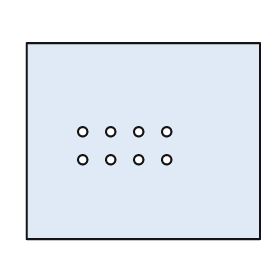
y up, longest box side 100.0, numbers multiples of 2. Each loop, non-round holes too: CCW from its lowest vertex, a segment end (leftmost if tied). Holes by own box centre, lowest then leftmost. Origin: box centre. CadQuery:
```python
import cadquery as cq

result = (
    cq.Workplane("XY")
    .moveTo(-50.0, -42.0)
    .lineTo(50.0, -42.0)
    .lineTo(50.0, 42.0)
    .lineTo(-50.0, 42.0)
    .close()
    .moveTo(-26.0, -8.0)
    .circle(2.0)
    .moveTo(-14.0, -8.0)
    .circle(2.0)
    .moveTo(-2.0, -8.0)
    .circle(2.0)
    .moveTo(10.0, -8.0)
    .circle(2.0)
    .moveTo(-26.0, 4.0)
    .circle(2.0)
    .moveTo(-14.0, 4.0)
    .circle(2.0)
    .moveTo(-2.0, 4.0)
    .circle(2.0)
    .moveTo(10.0, 4.0)
    .circle(2.0)
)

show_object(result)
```